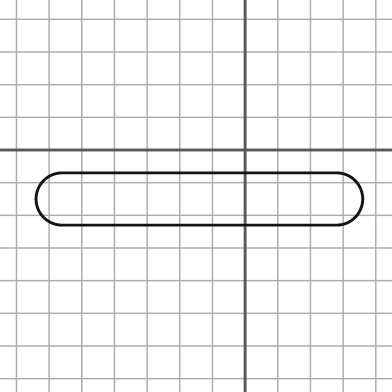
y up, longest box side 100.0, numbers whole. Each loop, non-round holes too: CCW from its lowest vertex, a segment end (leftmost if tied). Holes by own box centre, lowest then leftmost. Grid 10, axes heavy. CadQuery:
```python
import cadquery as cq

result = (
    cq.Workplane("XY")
    .moveTo(-56.0, -23.0)
    .lineTo(28.0, -23.0)
    .threePointArc((36.0, -15.0), (28.0, -7.0))
    .lineTo(-56.0, -7.0)
    .threePointArc((-64.0, -15.0), (-56.0, -23.0))
    .close()
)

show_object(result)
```